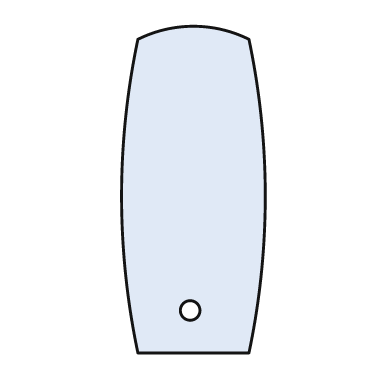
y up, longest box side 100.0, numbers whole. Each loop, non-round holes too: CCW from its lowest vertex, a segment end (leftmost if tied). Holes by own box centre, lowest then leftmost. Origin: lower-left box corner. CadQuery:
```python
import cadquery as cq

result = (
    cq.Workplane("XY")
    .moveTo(5.0, 0.0)
    .lineTo(39.0, 0.0)
    .threePointArc((44.0, 48.0), (39.0, 96.0))
    .threePointArc((22.0, 100.0), (5.0, 96.0))
    .threePointArc((0.0, 48.0), (5.0, 0.0))
    .close()
    .moveTo(21.0, 13.0)
    .circle(3.0)
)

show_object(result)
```